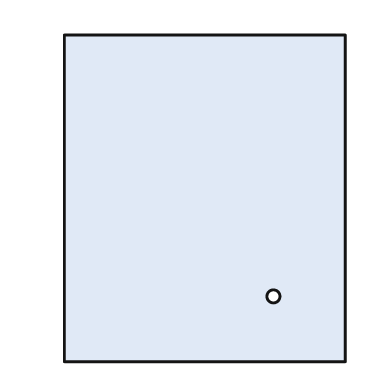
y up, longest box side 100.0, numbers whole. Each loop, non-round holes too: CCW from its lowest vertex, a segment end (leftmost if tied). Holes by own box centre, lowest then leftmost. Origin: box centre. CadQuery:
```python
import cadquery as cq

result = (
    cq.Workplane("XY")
    .moveTo(-43.0, -50.0)
    .lineTo(43.0, -50.0)
    .lineTo(43.0, 50.0)
    .lineTo(-43.0, 50.0)
    .close()
    .moveTo(21.0, -30.0)
    .circle(2.0)
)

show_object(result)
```